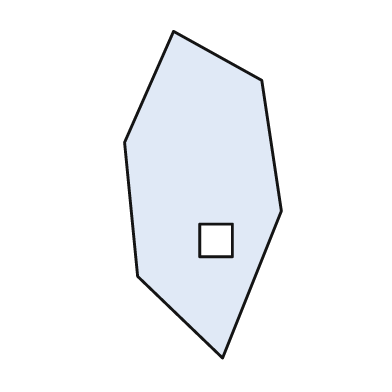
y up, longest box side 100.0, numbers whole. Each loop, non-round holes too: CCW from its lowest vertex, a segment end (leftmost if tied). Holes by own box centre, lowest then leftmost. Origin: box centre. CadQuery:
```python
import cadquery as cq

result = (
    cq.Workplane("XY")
    .moveTo(6.0, -50.0)
    .lineTo(24.0, -5.0)
    .lineTo(18.0, 35.0)
    .lineTo(-9.0, 50.0)
    .lineTo(-24.0, 16.0)
    .lineTo(-20.0, -25.0)
    .close()
    .moveTo(-1.0, -19.0)
    .lineTo(9.0, -19.0)
    .lineTo(9.0, -9.0)
    .lineTo(-1.0, -9.0)
    .close()
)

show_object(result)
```